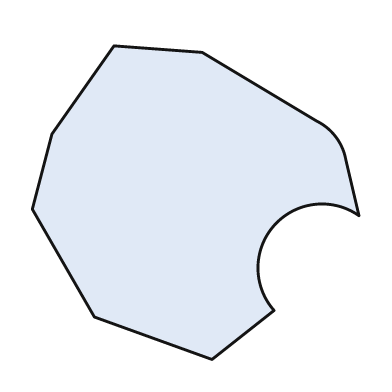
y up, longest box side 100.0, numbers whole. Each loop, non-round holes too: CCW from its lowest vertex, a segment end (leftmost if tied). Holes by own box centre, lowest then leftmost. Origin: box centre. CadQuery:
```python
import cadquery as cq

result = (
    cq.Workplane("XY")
    .moveTo(5.0, -48.0)
    .lineTo(24.0, -33.0)
    .threePointArc((24.0, -7.0), (50.0, -4.0))
    .lineTo(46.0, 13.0)
    .threePointArc((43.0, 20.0), (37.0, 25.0))
    .lineTo(2.0, 46.0)
    .lineTo(-25.0, 48.0)
    .lineTo(-44.0, 21.0)
    .lineTo(-50.0, -2.0)
    .lineTo(-31.0, -35.0)
    .close()
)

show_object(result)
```